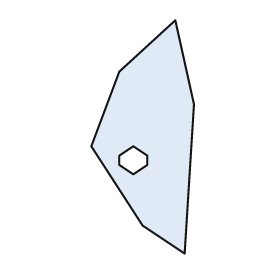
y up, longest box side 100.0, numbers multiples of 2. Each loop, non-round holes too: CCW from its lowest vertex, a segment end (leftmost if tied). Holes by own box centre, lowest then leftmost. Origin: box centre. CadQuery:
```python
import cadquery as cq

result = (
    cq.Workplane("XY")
    .moveTo(18.0, -50.0)
    .lineTo(22.0, 14.0)
    .lineTo(14.0, 50.0)
    .lineTo(-10.0, 28.0)
    .lineTo(-22.0, -4.0)
    .lineTo(0.0, -38.0)
    .close()
    .moveTo(-4.0, -16.0)
    .lineTo(2.0, -12.0)
    .lineTo(2.0, -8.0)
    .lineTo(-4.0, -4.0)
    .lineTo(-10.0, -8.0)
    .lineTo(-10.0, -12.0)
    .close()
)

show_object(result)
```